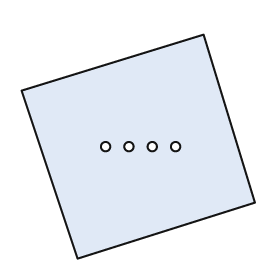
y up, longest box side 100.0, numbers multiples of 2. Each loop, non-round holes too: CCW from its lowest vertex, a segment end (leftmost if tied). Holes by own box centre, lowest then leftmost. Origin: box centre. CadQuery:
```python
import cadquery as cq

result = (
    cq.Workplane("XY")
    .moveTo(-26.0, -48.0)
    .lineTo(50.0, -24.0)
    .lineTo(28.0, 48.0)
    .lineTo(-50.0, 24.0)
    .close()
    .moveTo(-14.0, 0.0)
    .circle(2.0)
    .moveTo(-4.0, 0.0)
    .circle(2.0)
    .moveTo(6.0, 0.0)
    .circle(2.0)
    .moveTo(16.0, 0.0)
    .circle(2.0)
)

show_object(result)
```